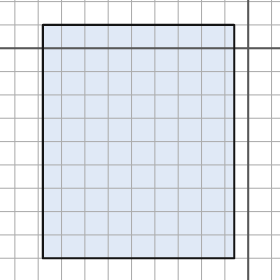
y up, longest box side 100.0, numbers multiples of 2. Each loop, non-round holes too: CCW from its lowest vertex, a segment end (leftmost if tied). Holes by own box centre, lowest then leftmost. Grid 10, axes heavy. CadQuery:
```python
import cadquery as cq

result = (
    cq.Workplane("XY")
    .moveTo(-88.0, -90.0)
    .lineTo(-6.0, -90.0)
    .lineTo(-6.0, 10.0)
    .lineTo(-88.0, 10.0)
    .close()
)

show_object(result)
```